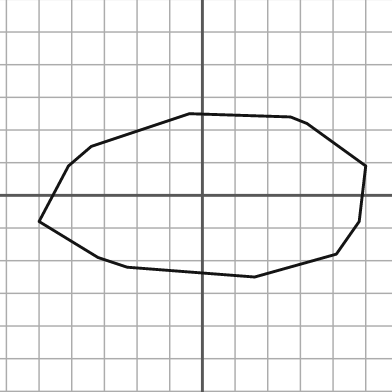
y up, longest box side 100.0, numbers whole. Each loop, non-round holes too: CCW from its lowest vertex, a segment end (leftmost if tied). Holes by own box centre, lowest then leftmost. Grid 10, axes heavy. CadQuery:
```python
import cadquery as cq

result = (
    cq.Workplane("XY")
    .moveTo(16.0, -25.0)
    .lineTo(41.0, -18.0)
    .lineTo(48.0, -8.0)
    .lineTo(50.0, 9.0)
    .lineTo(32.0, 22.0)
    .lineTo(27.0, 24.0)
    .lineTo(-4.0, 25.0)
    .lineTo(-34.0, 15.0)
    .lineTo(-41.0, 9.0)
    .lineTo(-50.0, -8.0)
    .lineTo(-32.0, -19.0)
    .lineTo(-23.0, -22.0)
    .close()
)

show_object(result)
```